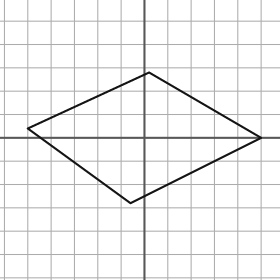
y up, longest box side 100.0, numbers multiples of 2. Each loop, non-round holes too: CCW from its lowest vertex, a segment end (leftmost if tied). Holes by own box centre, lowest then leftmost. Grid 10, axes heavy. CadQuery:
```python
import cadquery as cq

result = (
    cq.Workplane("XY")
    .moveTo(-6.0, -28.0)
    .lineTo(50.0, 0.0)
    .lineTo(2.0, 28.0)
    .lineTo(-50.0, 4.0)
    .close()
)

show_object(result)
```